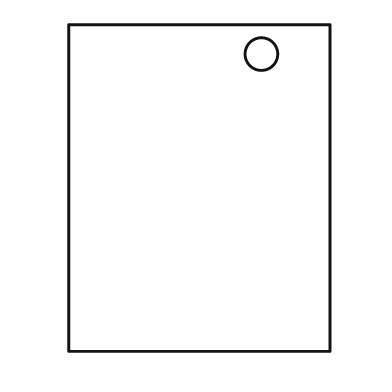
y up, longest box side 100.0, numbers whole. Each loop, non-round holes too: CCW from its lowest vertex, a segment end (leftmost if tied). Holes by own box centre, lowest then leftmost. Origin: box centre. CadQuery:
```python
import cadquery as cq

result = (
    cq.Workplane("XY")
    .moveTo(-40.0, -50.0)
    .lineTo(40.0, -50.0)
    .lineTo(40.0, 50.0)
    .lineTo(-40.0, 50.0)
    .close()
    .moveTo(19.0, 41.0)
    .circle(5.0)
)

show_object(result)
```